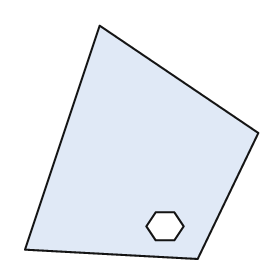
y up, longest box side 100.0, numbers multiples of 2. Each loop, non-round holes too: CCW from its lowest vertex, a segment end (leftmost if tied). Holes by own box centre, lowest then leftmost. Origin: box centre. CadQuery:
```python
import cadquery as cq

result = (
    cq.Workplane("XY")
    .moveTo(24.0, -50.0)
    .lineTo(50.0, 4.0)
    .lineTo(-18.0, 50.0)
    .lineTo(-50.0, -46.0)
    .close()
    .moveTo(6.0, -42.0)
    .lineTo(14.0, -42.0)
    .lineTo(18.0, -36.0)
    .lineTo(14.0, -30.0)
    .lineTo(6.0, -30.0)
    .lineTo(2.0, -36.0)
    .close()
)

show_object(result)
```